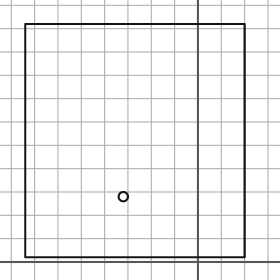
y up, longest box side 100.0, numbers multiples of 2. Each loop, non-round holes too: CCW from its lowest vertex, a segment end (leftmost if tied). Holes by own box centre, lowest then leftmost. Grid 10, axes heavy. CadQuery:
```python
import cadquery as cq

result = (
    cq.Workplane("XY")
    .moveTo(-74.0, 2.0)
    .lineTo(20.0, 2.0)
    .lineTo(20.0, 102.0)
    .lineTo(-74.0, 102.0)
    .close()
    .moveTo(-32.0, 28.0)
    .circle(2.0)
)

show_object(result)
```